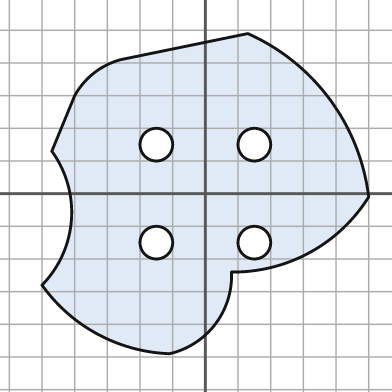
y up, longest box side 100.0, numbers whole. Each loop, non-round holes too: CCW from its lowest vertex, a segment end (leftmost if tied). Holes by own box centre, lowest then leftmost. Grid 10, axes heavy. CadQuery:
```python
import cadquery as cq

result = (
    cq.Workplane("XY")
    .moveTo(-11.0, -49.0)
    .threePointArc((3.0, -40.0), (8.0, -24.0))
    .threePointArc((32.0, -18.0), (50.0, -1.0))
    .threePointArc((38.0, 29.0), (13.0, 49.0))
    .lineTo(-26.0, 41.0)
    .threePointArc((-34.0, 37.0), (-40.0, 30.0))
    .lineTo(-47.0, 13.0)
    .threePointArc((-41.0, -8.0), (-50.0, -28.0))
    .threePointArc((-33.0, -43.0), (-11.0, -49.0))
    .close()
    .moveTo(-15.0, -15.0)
    .circle(5.0)
    .moveTo(15.0, -15.0)
    .circle(5.0)
    .moveTo(-15.0, 15.0)
    .circle(5.0)
    .moveTo(15.0, 15.0)
    .circle(5.0)
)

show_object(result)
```